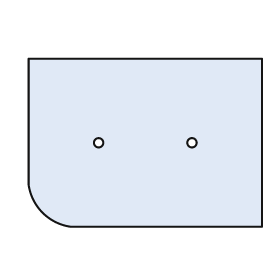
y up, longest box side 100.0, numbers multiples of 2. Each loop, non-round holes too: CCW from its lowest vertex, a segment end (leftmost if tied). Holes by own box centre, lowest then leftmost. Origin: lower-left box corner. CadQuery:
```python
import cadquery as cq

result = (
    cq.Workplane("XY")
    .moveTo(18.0, 0.0)
    .lineTo(100.0, 0.0)
    .lineTo(100.0, 72.0)
    .lineTo(0.0, 72.0)
    .lineTo(0.0, 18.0)
    .threePointArc((6.0, 6.0), (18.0, 0.0))
    .close()
    .moveTo(30.0, 36.0)
    .circle(2.0)
    .moveTo(70.0, 36.0)
    .circle(2.0)
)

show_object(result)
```